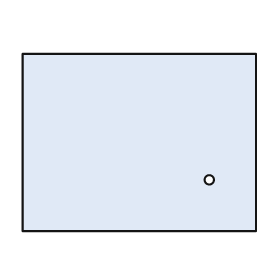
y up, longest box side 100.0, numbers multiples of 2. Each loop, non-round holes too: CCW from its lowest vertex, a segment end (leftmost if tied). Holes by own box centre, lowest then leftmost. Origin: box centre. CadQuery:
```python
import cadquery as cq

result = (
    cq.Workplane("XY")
    .moveTo(-50.0, -38.0)
    .lineTo(50.0, -38.0)
    .lineTo(50.0, 38.0)
    .lineTo(-50.0, 38.0)
    .close()
    .moveTo(30.0, -16.0)
    .circle(2.0)
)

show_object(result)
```